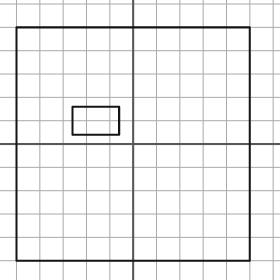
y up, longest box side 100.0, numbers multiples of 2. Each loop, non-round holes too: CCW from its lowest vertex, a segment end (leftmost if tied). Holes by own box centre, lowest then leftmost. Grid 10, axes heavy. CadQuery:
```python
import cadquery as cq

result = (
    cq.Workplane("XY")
    .moveTo(-50.0, -50.0)
    .lineTo(50.0, -50.0)
    .lineTo(50.0, 50.0)
    .lineTo(-50.0, 50.0)
    .close()
    .moveTo(-26.0, 4.0)
    .lineTo(-6.0, 4.0)
    .lineTo(-6.0, 16.0)
    .lineTo(-26.0, 16.0)
    .close()
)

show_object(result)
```